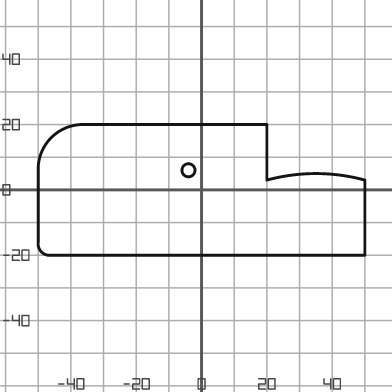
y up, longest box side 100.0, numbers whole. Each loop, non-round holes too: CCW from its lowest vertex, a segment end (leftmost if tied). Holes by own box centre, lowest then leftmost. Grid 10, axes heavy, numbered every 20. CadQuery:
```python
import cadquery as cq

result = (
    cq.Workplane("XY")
    .moveTo(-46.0, -20.0)
    .lineTo(50.0, -20.0)
    .lineTo(50.0, 3.0)
    .threePointArc((35.0, 5.0), (20.0, 3.0))
    .lineTo(20.0, 20.0)
    .lineTo(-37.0, 20.0)
    .threePointArc((-46.0, 16.0), (-50.0, 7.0))
    .lineTo(-50.0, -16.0)
    .threePointArc((-49.0, -19.0), (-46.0, -20.0))
    .close()
    .moveTo(-4.0, 6.0)
    .circle(2.0)
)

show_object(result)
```